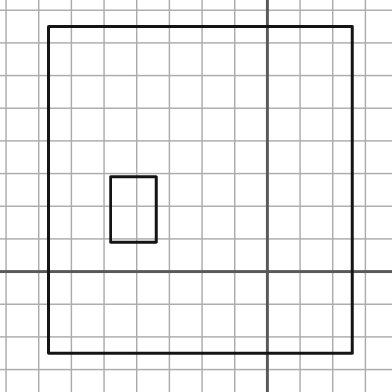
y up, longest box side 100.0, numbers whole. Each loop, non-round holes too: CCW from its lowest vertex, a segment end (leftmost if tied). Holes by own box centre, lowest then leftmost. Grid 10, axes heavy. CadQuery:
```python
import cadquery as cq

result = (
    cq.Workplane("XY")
    .moveTo(-67.0, -25.0)
    .lineTo(26.0, -25.0)
    .lineTo(26.0, 75.0)
    .lineTo(-67.0, 75.0)
    .close()
    .moveTo(-48.0, 9.0)
    .lineTo(-34.0, 9.0)
    .lineTo(-34.0, 29.0)
    .lineTo(-48.0, 29.0)
    .close()
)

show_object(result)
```